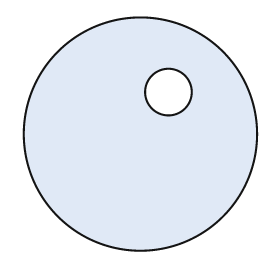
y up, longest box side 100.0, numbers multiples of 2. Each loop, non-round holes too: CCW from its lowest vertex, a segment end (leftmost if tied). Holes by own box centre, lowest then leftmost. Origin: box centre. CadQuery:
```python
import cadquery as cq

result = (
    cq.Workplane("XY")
    .moveTo(0.0, 0.0)
    .circle(50.0)
    .moveTo(12.0, 18.0)
    .circle(10.0)
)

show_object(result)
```